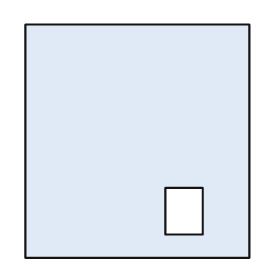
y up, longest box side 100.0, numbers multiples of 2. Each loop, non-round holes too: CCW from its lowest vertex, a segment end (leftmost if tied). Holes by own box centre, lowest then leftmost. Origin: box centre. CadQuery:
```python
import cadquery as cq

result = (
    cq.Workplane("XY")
    .moveTo(-48.0, -50.0)
    .lineTo(48.0, -50.0)
    .lineTo(48.0, 50.0)
    .lineTo(-48.0, 50.0)
    .close()
    .moveTo(12.0, -40.0)
    .lineTo(28.0, -40.0)
    .lineTo(28.0, -20.0)
    .lineTo(12.0, -20.0)
    .close()
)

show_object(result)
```